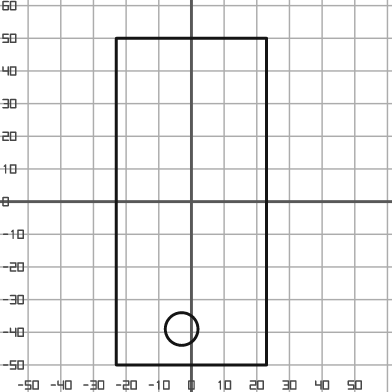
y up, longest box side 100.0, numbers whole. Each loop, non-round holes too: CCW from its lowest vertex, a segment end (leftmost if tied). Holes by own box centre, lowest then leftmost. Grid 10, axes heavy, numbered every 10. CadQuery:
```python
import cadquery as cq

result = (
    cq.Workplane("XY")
    .moveTo(-23.0, -50.0)
    .lineTo(23.0, -50.0)
    .lineTo(23.0, 50.0)
    .lineTo(-23.0, 50.0)
    .close()
    .moveTo(-3.0, -39.0)
    .circle(5.0)
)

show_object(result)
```